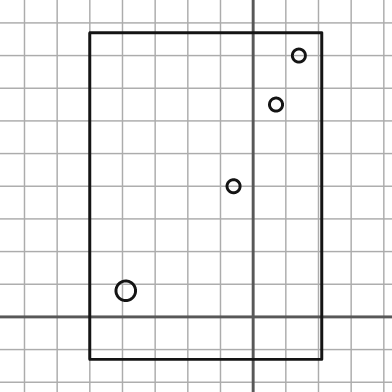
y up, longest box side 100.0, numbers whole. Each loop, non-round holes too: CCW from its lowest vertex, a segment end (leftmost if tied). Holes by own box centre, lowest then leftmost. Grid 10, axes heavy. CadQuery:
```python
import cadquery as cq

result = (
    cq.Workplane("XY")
    .moveTo(-50.0, -13.0)
    .lineTo(21.0, -13.0)
    .lineTo(21.0, 87.0)
    .lineTo(-50.0, 87.0)
    .close()
    .moveTo(-39.0, 8.0)
    .circle(3.0)
    .moveTo(-6.0, 40.0)
    .circle(2.0)
    .moveTo(7.0, 65.0)
    .circle(2.0)
    .moveTo(14.0, 80.0)
    .circle(2.0)
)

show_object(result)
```